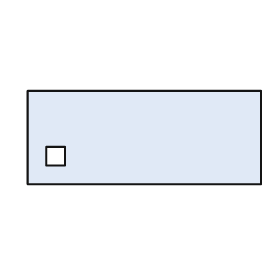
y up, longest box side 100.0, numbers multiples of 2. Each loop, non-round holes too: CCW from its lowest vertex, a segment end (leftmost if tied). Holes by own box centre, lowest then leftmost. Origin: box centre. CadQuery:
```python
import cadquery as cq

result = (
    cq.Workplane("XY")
    .moveTo(-50.0, -20.0)
    .lineTo(50.0, -20.0)
    .lineTo(50.0, 20.0)
    .lineTo(-50.0, 20.0)
    .close()
    .moveTo(-42.0, -12.0)
    .lineTo(-34.0, -12.0)
    .lineTo(-34.0, -4.0)
    .lineTo(-42.0, -4.0)
    .close()
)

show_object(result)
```